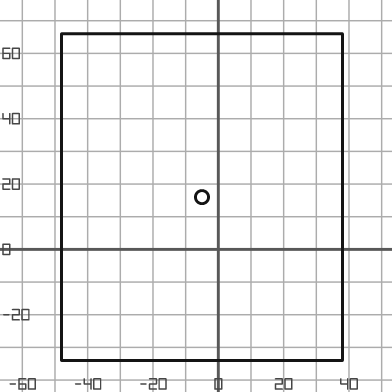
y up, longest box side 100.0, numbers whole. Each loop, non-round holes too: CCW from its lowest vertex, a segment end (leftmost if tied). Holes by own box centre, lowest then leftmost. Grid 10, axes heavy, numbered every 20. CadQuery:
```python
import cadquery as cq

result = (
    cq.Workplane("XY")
    .moveTo(-48.0, -34.0)
    .lineTo(38.0, -34.0)
    .lineTo(38.0, 66.0)
    .lineTo(-48.0, 66.0)
    .close()
    .moveTo(-5.0, 16.0)
    .circle(2.0)
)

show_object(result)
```